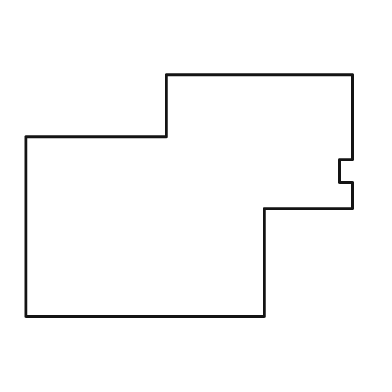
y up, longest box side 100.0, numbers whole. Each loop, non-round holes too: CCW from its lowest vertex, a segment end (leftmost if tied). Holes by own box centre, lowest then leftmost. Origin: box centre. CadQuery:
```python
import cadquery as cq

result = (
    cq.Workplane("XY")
    .moveTo(-50.0, -37.0)
    .lineTo(23.0, -37.0)
    .lineTo(23.0, -4.0)
    .lineTo(50.0, -4.0)
    .lineTo(50.0, 4.0)
    .lineTo(46.0, 4.0)
    .lineTo(46.0, 11.0)
    .lineTo(50.0, 11.0)
    .lineTo(50.0, 37.0)
    .lineTo(-7.0, 37.0)
    .lineTo(-7.0, 18.0)
    .lineTo(-50.0, 18.0)
    .close()
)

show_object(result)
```